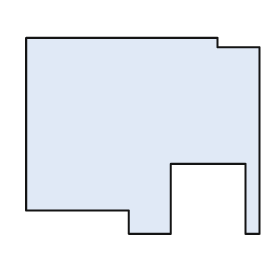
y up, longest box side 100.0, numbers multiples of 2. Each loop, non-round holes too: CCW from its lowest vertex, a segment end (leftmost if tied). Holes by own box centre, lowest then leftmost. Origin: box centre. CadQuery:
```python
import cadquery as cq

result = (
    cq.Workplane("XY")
    .moveTo(-6.0, -42.0)
    .lineTo(12.0, -42.0)
    .lineTo(12.0, -12.0)
    .lineTo(44.0, -12.0)
    .lineTo(44.0, -42.0)
    .lineTo(50.0, -42.0)
    .lineTo(50.0, 38.0)
    .lineTo(32.0, 38.0)
    .lineTo(32.0, 42.0)
    .lineTo(-50.0, 42.0)
    .lineTo(-50.0, -32.0)
    .lineTo(-6.0, -32.0)
    .close()
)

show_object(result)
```